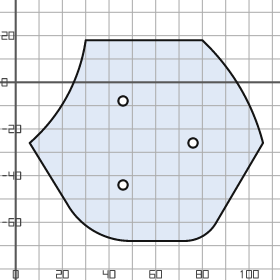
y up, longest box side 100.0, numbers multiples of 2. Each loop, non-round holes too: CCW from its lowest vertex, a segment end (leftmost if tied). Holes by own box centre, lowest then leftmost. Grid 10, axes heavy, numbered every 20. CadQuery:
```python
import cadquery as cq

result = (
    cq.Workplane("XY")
    .moveTo(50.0, -68.0)
    .lineTo(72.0, -68.0)
    .threePointArc((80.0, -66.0), (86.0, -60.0))
    .lineTo(106.0, -26.0)
    .threePointArc((96.0, -2.0), (80.0, 18.0))
    .lineTo(30.0, 18.0)
    .threePointArc((22.0, -6.0), (6.0, -26.0))
    .lineTo(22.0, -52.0)
    .threePointArc((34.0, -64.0), (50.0, -68.0))
    .close()
    .moveTo(46.0, -44.0)
    .circle(2.0)
    .moveTo(76.0, -26.0)
    .circle(2.0)
    .moveTo(46.0, -8.0)
    .circle(2.0)
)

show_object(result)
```